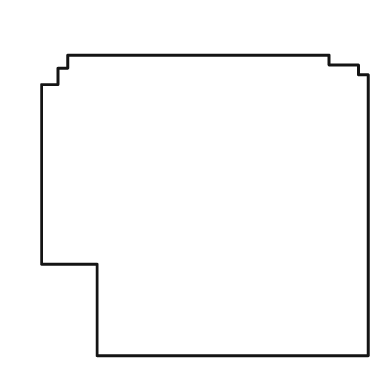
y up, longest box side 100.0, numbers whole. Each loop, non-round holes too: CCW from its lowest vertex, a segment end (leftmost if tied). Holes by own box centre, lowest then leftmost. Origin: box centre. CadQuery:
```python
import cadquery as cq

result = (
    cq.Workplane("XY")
    .moveTo(-33.0, -46.0)
    .lineTo(50.0, -46.0)
    .lineTo(50.0, 40.0)
    .lineTo(47.0, 40.0)
    .lineTo(47.0, 43.0)
    .lineTo(38.0, 43.0)
    .lineTo(38.0, 46.0)
    .lineTo(-42.0, 46.0)
    .lineTo(-42.0, 42.0)
    .lineTo(-45.0, 42.0)
    .lineTo(-45.0, 37.0)
    .lineTo(-50.0, 37.0)
    .lineTo(-50.0, -18.0)
    .lineTo(-33.0, -18.0)
    .close()
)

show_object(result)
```